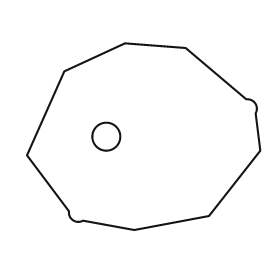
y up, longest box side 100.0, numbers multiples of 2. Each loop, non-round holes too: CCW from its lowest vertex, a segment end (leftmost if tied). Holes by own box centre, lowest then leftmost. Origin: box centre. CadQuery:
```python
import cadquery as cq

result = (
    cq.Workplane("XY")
    .moveTo(-4.0, -40.0)
    .lineTo(28.0, -34.0)
    .lineTo(50.0, -6.0)
    .lineTo(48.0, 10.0)
    .threePointArc((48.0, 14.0), (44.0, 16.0))
    .lineTo(18.0, 38.0)
    .lineTo(-8.0, 40.0)
    .lineTo(-34.0, 28.0)
    .lineTo(-50.0, -8.0)
    .lineTo(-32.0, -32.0)
    .threePointArc((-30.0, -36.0), (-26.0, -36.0))
    .close()
    .moveTo(-16.0, 0.0)
    .circle(6.0)
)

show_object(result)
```